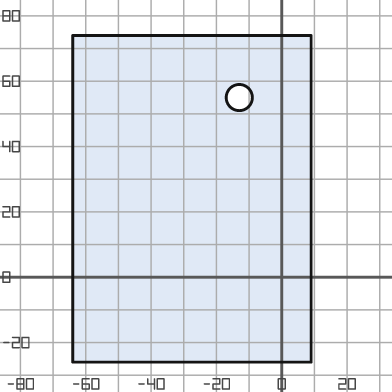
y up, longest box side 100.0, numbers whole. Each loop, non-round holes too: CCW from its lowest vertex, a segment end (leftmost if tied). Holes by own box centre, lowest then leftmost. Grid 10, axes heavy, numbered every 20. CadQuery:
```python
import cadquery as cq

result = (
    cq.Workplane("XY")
    .moveTo(-64.0, -26.0)
    .lineTo(9.0, -26.0)
    .lineTo(9.0, 74.0)
    .lineTo(-64.0, 74.0)
    .close()
    .moveTo(-13.0, 55.0)
    .circle(4.0)
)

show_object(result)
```